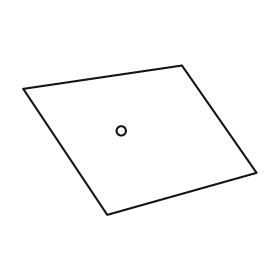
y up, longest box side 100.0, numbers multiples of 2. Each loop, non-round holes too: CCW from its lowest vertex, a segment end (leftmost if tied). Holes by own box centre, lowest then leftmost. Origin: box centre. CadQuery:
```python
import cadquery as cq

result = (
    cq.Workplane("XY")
    .moveTo(-14.0, -32.0)
    .lineTo(50.0, -14.0)
    .lineTo(18.0, 32.0)
    .lineTo(-50.0, 22.0)
    .close()
    .moveTo(-8.0, 4.0)
    .circle(2.0)
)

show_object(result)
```